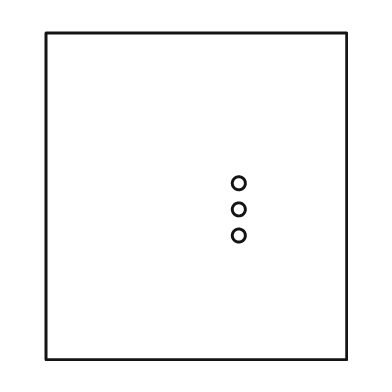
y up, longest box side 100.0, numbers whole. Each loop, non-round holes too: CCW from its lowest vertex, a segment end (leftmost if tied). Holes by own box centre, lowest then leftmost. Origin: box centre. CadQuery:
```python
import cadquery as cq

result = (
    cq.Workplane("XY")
    .moveTo(-46.0, -50.0)
    .lineTo(46.0, -50.0)
    .lineTo(46.0, 50.0)
    .lineTo(-46.0, 50.0)
    .close()
    .moveTo(13.0, -12.0)
    .circle(2.0)
    .moveTo(13.0, -4.0)
    .circle(2.0)
    .moveTo(13.0, 4.0)
    .circle(2.0)
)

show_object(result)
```